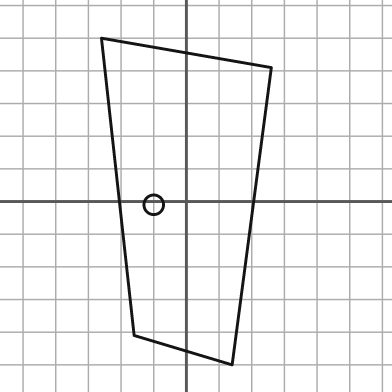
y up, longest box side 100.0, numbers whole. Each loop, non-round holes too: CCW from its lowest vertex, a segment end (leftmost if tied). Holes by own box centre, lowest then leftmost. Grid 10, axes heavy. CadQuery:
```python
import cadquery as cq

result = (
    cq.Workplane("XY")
    .moveTo(14.0, -50.0)
    .lineTo(26.0, 41.0)
    .lineTo(-26.0, 50.0)
    .lineTo(-16.0, -41.0)
    .close()
    .moveTo(-10.0, -1.0)
    .circle(3.0)
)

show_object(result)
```